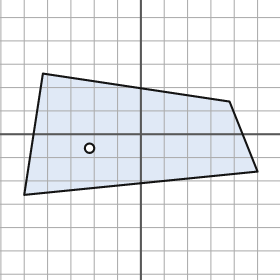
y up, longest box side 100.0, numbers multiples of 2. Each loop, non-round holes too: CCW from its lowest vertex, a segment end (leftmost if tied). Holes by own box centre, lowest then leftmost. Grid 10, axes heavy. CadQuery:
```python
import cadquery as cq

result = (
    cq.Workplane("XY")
    .moveTo(-50.0, -26.0)
    .lineTo(50.0, -16.0)
    .lineTo(38.0, 14.0)
    .lineTo(-42.0, 26.0)
    .close()
    .moveTo(-22.0, -6.0)
    .circle(2.0)
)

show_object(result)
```